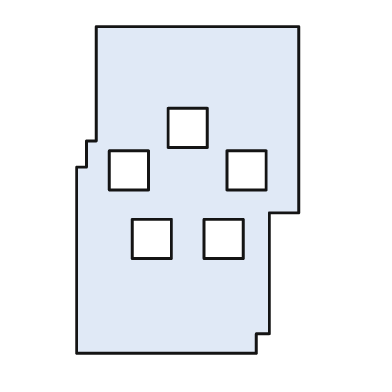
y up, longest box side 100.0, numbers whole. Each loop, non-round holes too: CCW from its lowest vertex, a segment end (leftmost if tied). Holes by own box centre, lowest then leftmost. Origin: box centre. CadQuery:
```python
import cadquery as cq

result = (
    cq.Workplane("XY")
    .moveTo(-34.0, -50.0)
    .lineTo(21.0, -50.0)
    .lineTo(21.0, -44.0)
    .lineTo(25.0, -44.0)
    .lineTo(25.0, -7.0)
    .lineTo(34.0, -7.0)
    .lineTo(34.0, 50.0)
    .lineTo(-28.0, 50.0)
    .lineTo(-28.0, 15.0)
    .lineTo(-31.0, 15.0)
    .lineTo(-31.0, 7.0)
    .lineTo(-34.0, 7.0)
    .close()
    .moveTo(-17.0, -21.0)
    .lineTo(-5.0, -21.0)
    .lineTo(-5.0, -9.0)
    .lineTo(-17.0, -9.0)
    .close()
    .moveTo(5.0, -21.0)
    .lineTo(17.0, -21.0)
    .lineTo(17.0, -9.0)
    .lineTo(5.0, -9.0)
    .close()
    .moveTo(-24.0, 0.0)
    .lineTo(-12.0, 0.0)
    .lineTo(-12.0, 12.0)
    .lineTo(-24.0, 12.0)
    .close()
    .moveTo(12.0, 0.0)
    .lineTo(24.0, 0.0)
    .lineTo(24.0, 12.0)
    .lineTo(12.0, 12.0)
    .close()
    .moveTo(-6.0, 13.0)
    .lineTo(6.0, 13.0)
    .lineTo(6.0, 25.0)
    .lineTo(-6.0, 25.0)
    .close()
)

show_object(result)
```